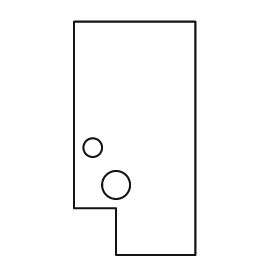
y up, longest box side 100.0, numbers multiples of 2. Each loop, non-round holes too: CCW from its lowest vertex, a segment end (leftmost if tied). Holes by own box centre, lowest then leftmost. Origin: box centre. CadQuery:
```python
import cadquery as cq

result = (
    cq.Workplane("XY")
    .moveTo(-8.0, -50.0)
    .lineTo(26.0, -50.0)
    .lineTo(26.0, 50.0)
    .lineTo(-26.0, 50.0)
    .lineTo(-26.0, -30.0)
    .lineTo(-8.0, -30.0)
    .close()
    .moveTo(-8.0, -20.0)
    .circle(6.0)
    .moveTo(-18.0, -4.0)
    .circle(4.0)
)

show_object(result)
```